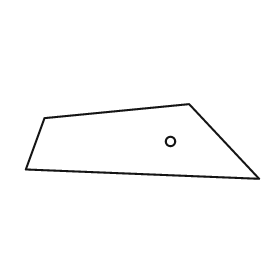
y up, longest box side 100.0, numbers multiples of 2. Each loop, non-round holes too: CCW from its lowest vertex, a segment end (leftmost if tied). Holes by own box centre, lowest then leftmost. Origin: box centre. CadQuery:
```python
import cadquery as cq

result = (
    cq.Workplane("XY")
    .moveTo(50.0, -16.0)
    .lineTo(20.0, 16.0)
    .lineTo(-42.0, 10.0)
    .lineTo(-50.0, -12.0)
    .close()
    .moveTo(12.0, 0.0)
    .circle(2.0)
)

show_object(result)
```